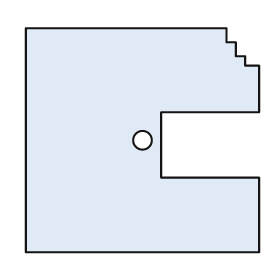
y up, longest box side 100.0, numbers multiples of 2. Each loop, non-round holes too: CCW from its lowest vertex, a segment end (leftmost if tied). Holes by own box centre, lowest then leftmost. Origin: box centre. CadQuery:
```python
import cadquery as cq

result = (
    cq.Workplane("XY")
    .moveTo(-50.0, -48.0)
    .lineTo(50.0, -48.0)
    .lineTo(50.0, -16.0)
    .lineTo(8.0, -16.0)
    .lineTo(8.0, 12.0)
    .lineTo(50.0, 12.0)
    .lineTo(50.0, 32.0)
    .lineTo(44.0, 32.0)
    .lineTo(44.0, 36.0)
    .lineTo(40.0, 36.0)
    .lineTo(40.0, 42.0)
    .lineTo(36.0, 42.0)
    .lineTo(36.0, 48.0)
    .lineTo(-50.0, 48.0)
    .close()
    .moveTo(0.0, 0.0)
    .circle(4.0)
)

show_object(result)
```